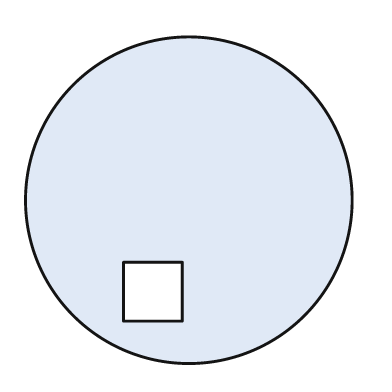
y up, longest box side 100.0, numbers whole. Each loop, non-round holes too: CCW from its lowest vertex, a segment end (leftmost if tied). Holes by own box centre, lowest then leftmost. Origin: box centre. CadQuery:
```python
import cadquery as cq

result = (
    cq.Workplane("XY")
    .moveTo(0.0, 0.0)
    .circle(50.0)
    .moveTo(-20.0, -37.0)
    .lineTo(-2.0, -37.0)
    .lineTo(-2.0, -19.0)
    .lineTo(-20.0, -19.0)
    .close()
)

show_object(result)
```